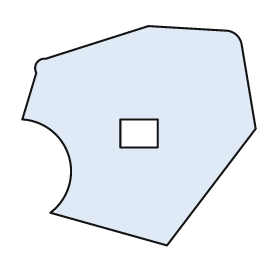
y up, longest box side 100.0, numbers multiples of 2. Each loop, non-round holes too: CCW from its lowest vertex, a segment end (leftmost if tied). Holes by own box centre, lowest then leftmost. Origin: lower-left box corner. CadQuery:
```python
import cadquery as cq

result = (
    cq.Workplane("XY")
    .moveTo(62.0, 0.0)
    .lineTo(100.0, 50.0)
    .lineTo(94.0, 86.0)
    .threePointArc((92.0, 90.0), (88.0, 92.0))
    .lineTo(54.0, 94.0)
    .lineTo(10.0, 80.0)
    .threePointArc((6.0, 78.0), (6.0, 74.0))
    .lineTo(0.0, 54.0)
    .threePointArc((20.0, 38.0), (12.0, 14.0))
    .close()
    .moveTo(42.0, 42.0)
    .lineTo(58.0, 42.0)
    .lineTo(58.0, 54.0)
    .lineTo(42.0, 54.0)
    .close()
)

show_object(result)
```